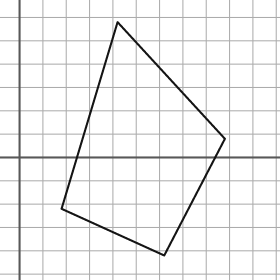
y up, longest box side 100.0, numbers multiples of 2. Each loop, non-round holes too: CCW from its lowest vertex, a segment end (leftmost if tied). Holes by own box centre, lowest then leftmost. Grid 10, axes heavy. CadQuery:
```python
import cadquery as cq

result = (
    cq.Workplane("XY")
    .moveTo(62.0, -42.0)
    .lineTo(88.0, 8.0)
    .lineTo(42.0, 58.0)
    .lineTo(18.0, -22.0)
    .close()
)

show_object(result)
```